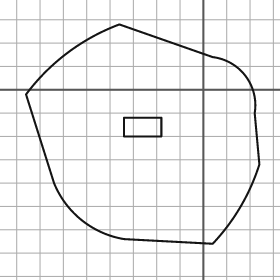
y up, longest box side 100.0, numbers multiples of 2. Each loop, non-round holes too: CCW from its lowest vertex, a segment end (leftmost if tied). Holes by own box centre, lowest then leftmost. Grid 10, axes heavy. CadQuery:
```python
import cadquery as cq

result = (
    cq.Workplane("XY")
    .moveTo(4.0, -66.0)
    .threePointArc((16.0, -50.0), (24.0, -32.0))
    .lineTo(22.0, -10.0)
    .threePointArc((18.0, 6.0), (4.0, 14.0))
    .lineTo(-36.0, 28.0)
    .threePointArc((-58.0, 16.0), (-76.0, -2.0))
    .lineTo(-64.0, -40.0)
    .threePointArc((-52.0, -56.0), (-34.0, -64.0))
    .close()
    .moveTo(-34.0, -20.0)
    .lineTo(-18.0, -20.0)
    .lineTo(-18.0, -12.0)
    .lineTo(-34.0, -12.0)
    .close()
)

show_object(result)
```